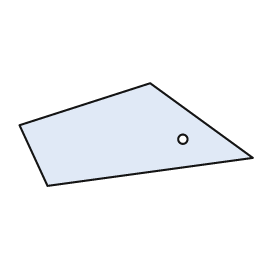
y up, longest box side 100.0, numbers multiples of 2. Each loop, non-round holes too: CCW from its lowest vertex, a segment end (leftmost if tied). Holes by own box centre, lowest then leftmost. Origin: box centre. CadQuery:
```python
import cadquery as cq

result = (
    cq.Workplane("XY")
    .moveTo(-38.0, -22.0)
    .lineTo(50.0, -10.0)
    .lineTo(6.0, 22.0)
    .lineTo(-50.0, 4.0)
    .close()
    .moveTo(20.0, -2.0)
    .circle(2.0)
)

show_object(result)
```